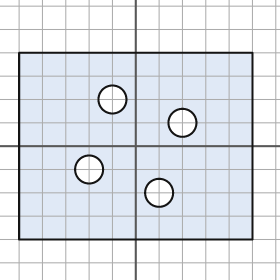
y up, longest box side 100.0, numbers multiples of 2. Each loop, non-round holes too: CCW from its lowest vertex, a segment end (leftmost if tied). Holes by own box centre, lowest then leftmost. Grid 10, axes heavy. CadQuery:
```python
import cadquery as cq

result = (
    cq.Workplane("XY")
    .moveTo(-50.0, -40.0)
    .lineTo(50.0, -40.0)
    .lineTo(50.0, 40.0)
    .lineTo(-50.0, 40.0)
    .close()
    .moveTo(10.0, -20.0)
    .circle(6.0)
    .moveTo(-20.0, -10.0)
    .circle(6.0)
    .moveTo(20.0, 10.0)
    .circle(6.0)
    .moveTo(-10.0, 20.0)
    .circle(6.0)
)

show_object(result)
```